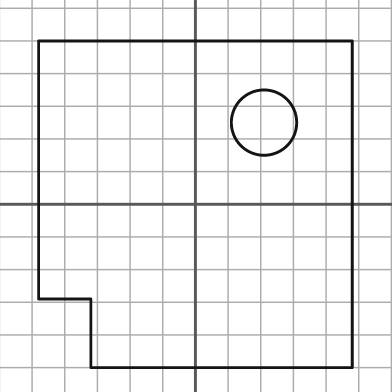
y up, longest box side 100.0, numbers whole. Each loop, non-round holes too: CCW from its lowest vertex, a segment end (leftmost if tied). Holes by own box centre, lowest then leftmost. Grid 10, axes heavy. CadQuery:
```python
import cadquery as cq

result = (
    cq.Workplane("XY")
    .moveTo(-32.0, -50.0)
    .lineTo(48.0, -50.0)
    .lineTo(48.0, 50.0)
    .lineTo(-48.0, 50.0)
    .lineTo(-48.0, -29.0)
    .lineTo(-32.0, -29.0)
    .close()
    .moveTo(21.0, 25.0)
    .circle(10.0)
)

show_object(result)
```